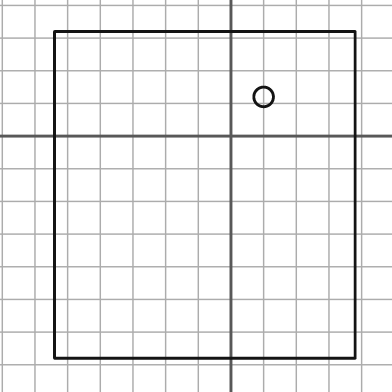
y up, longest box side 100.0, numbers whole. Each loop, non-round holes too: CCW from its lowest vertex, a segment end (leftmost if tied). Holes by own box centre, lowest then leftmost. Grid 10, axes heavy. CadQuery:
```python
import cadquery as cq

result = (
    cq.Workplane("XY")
    .moveTo(-54.0, -68.0)
    .lineTo(38.0, -68.0)
    .lineTo(38.0, 32.0)
    .lineTo(-54.0, 32.0)
    .close()
    .moveTo(10.0, 12.0)
    .circle(3.0)
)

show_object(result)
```